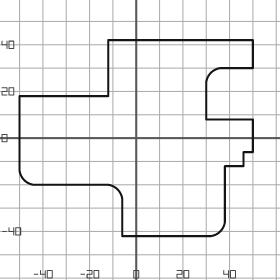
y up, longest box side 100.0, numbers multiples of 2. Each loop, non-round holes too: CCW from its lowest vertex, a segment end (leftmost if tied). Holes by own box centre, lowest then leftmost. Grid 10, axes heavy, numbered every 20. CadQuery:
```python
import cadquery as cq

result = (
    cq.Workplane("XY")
    .moveTo(-6.0, -42.0)
    .lineTo(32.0, -42.0)
    .threePointArc((36.0, -40.0), (38.0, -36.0))
    .lineTo(38.0, -12.0)
    .lineTo(46.0, -12.0)
    .lineTo(46.0, -6.0)
    .lineTo(50.0, -6.0)
    .lineTo(50.0, 8.0)
    .lineTo(30.0, 8.0)
    .lineTo(30.0, 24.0)
    .threePointArc((32.0, 28.0), (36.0, 30.0))
    .lineTo(50.0, 30.0)
    .lineTo(50.0, 42.0)
    .lineTo(-12.0, 42.0)
    .lineTo(-12.0, 18.0)
    .lineTo(-50.0, 18.0)
    .lineTo(-50.0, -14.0)
    .threePointArc((-48.0, -18.0), (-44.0, -20.0))
    .lineTo(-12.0, -20.0)
    .threePointArc((-8.0, -22.0), (-6.0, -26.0))
    .close()
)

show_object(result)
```